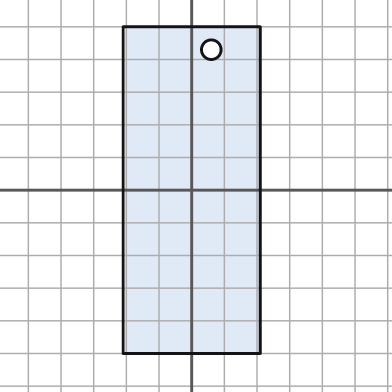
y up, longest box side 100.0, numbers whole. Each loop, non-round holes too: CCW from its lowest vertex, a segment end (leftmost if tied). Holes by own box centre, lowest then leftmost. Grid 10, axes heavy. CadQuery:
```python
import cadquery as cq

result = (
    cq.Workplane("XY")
    .moveTo(-21.0, -50.0)
    .lineTo(21.0, -50.0)
    .lineTo(21.0, 50.0)
    .lineTo(-21.0, 50.0)
    .close()
    .moveTo(6.0, 43.0)
    .circle(3.0)
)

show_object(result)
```